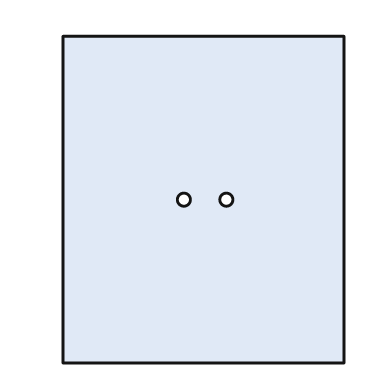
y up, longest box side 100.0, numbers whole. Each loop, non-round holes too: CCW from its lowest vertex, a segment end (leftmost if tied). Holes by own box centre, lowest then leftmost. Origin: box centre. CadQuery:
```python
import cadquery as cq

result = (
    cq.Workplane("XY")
    .moveTo(-43.0, -50.0)
    .lineTo(43.0, -50.0)
    .lineTo(43.0, 50.0)
    .lineTo(-43.0, 50.0)
    .close()
    .moveTo(-6.0, 0.0)
    .circle(2.0)
    .moveTo(7.0, 0.0)
    .circle(2.0)
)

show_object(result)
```